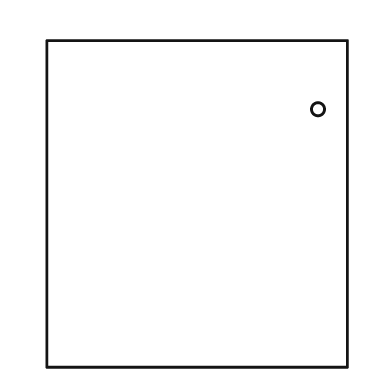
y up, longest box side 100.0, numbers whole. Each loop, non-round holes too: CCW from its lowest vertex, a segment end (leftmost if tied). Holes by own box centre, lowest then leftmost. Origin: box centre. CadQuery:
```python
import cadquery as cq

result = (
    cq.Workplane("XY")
    .moveTo(-46.0, -50.0)
    .lineTo(46.0, -50.0)
    .lineTo(46.0, 50.0)
    .lineTo(-46.0, 50.0)
    .close()
    .moveTo(37.0, 29.0)
    .circle(2.0)
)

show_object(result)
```